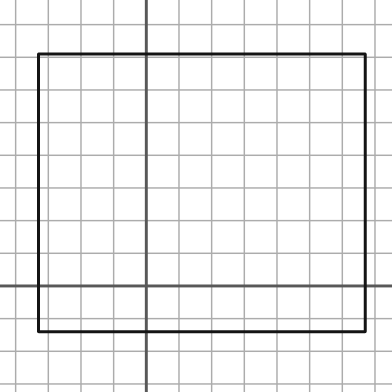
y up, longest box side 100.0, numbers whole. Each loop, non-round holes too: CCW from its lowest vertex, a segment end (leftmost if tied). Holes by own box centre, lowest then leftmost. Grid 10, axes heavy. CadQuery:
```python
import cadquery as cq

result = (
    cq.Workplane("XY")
    .moveTo(-33.0, -14.0)
    .lineTo(67.0, -14.0)
    .lineTo(67.0, 71.0)
    .lineTo(-33.0, 71.0)
    .close()
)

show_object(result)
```